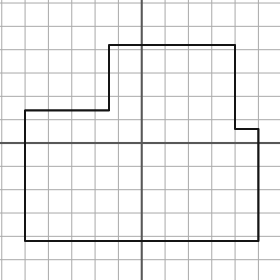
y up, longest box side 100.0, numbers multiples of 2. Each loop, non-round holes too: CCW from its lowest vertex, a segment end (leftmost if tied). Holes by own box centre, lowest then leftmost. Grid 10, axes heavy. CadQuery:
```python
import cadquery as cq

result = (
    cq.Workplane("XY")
    .moveTo(-50.0, -42.0)
    .lineTo(50.0, -42.0)
    .lineTo(50.0, 6.0)
    .lineTo(40.0, 6.0)
    .lineTo(40.0, 42.0)
    .lineTo(-14.0, 42.0)
    .lineTo(-14.0, 14.0)
    .lineTo(-50.0, 14.0)
    .close()
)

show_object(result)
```